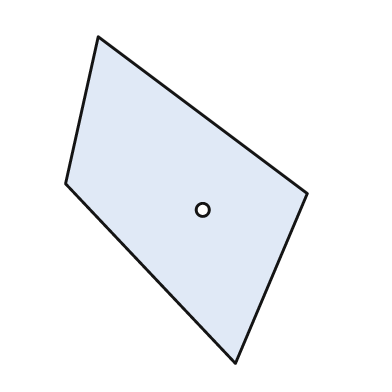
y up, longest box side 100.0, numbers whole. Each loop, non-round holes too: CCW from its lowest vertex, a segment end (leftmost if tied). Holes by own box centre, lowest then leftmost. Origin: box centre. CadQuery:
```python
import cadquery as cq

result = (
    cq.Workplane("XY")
    .moveTo(15.0, -50.0)
    .lineTo(37.0, 2.0)
    .lineTo(-27.0, 50.0)
    .lineTo(-37.0, 5.0)
    .close()
    .moveTo(5.0, -3.0)
    .circle(2.0)
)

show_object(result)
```